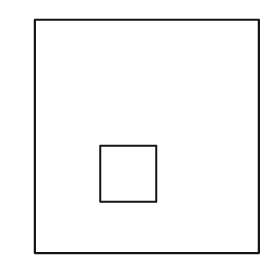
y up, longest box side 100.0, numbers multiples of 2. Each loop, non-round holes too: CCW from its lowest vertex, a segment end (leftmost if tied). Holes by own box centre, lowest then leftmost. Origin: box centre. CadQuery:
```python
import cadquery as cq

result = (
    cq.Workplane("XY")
    .moveTo(-48.0, -50.0)
    .lineTo(48.0, -50.0)
    .lineTo(48.0, 50.0)
    .lineTo(-48.0, 50.0)
    .close()
    .moveTo(-20.0, -28.0)
    .lineTo(4.0, -28.0)
    .lineTo(4.0, -4.0)
    .lineTo(-20.0, -4.0)
    .close()
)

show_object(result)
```